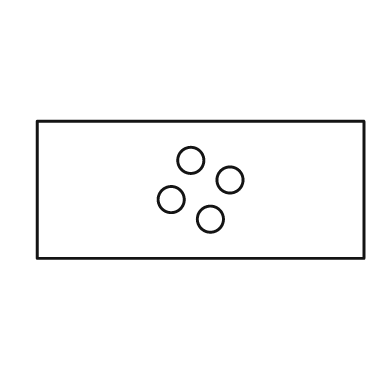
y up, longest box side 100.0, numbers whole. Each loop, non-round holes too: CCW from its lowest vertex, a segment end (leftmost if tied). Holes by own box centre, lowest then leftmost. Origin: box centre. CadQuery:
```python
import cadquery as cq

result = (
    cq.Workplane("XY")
    .moveTo(-50.0, -21.0)
    .lineTo(50.0, -21.0)
    .lineTo(50.0, 21.0)
    .lineTo(-50.0, 21.0)
    .close()
    .moveTo(3.0, -9.0)
    .circle(4.0)
    .moveTo(-9.0, -3.0)
    .circle(4.0)
    .moveTo(9.0, 3.0)
    .circle(4.0)
    .moveTo(-3.0, 9.0)
    .circle(4.0)
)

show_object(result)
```